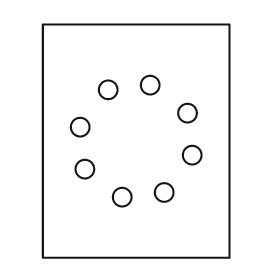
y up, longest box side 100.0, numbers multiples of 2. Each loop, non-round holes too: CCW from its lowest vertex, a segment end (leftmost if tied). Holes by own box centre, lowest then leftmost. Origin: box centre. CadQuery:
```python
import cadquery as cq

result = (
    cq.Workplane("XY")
    .moveTo(-40.0, -50.0)
    .lineTo(40.0, -50.0)
    .lineTo(40.0, 50.0)
    .lineTo(-40.0, 50.0)
    .close()
    .moveTo(-6.0, -24.0)
    .circle(4.0)
    .moveTo(12.0, -22.0)
    .circle(4.0)
    .moveTo(-22.0, -12.0)
    .circle(4.0)
    .moveTo(24.0, -6.0)
    .circle(4.0)
    .moveTo(-24.0, 6.0)
    .circle(4.0)
    .moveTo(22.0, 12.0)
    .circle(4.0)
    .moveTo(-12.0, 22.0)
    .circle(4.0)
    .moveTo(6.0, 24.0)
    .circle(4.0)
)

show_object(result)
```